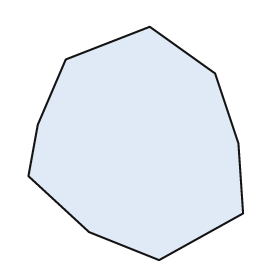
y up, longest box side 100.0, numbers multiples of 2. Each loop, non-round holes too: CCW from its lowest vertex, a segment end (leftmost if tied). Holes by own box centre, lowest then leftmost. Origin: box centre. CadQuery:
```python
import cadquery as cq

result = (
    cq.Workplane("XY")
    .moveTo(10.0, -50.0)
    .lineTo(46.0, -30.0)
    .lineTo(44.0, 0.0)
    .lineTo(34.0, 30.0)
    .lineTo(6.0, 50.0)
    .lineTo(-30.0, 36.0)
    .lineTo(-42.0, 8.0)
    .lineTo(-46.0, -14.0)
    .lineTo(-20.0, -38.0)
    .close()
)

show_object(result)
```